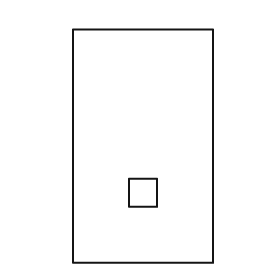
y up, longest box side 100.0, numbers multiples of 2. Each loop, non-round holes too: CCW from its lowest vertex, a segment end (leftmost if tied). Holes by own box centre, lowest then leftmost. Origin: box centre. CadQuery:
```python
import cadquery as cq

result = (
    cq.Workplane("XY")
    .moveTo(-30.0, -50.0)
    .lineTo(30.0, -50.0)
    .lineTo(30.0, 50.0)
    .lineTo(-30.0, 50.0)
    .close()
    .moveTo(-6.0, -26.0)
    .lineTo(6.0, -26.0)
    .lineTo(6.0, -14.0)
    .lineTo(-6.0, -14.0)
    .close()
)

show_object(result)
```